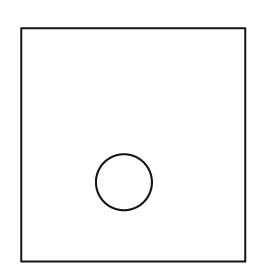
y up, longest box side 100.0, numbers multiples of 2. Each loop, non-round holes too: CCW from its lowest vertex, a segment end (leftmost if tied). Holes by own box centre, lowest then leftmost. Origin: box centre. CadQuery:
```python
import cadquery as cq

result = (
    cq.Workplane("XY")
    .moveTo(-48.0, -50.0)
    .lineTo(48.0, -50.0)
    .lineTo(48.0, 50.0)
    .lineTo(-48.0, 50.0)
    .close()
    .moveTo(-4.0, -16.0)
    .circle(12.0)
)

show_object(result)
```